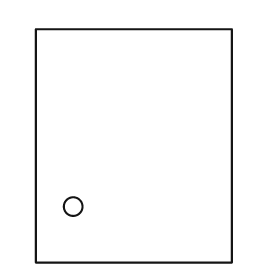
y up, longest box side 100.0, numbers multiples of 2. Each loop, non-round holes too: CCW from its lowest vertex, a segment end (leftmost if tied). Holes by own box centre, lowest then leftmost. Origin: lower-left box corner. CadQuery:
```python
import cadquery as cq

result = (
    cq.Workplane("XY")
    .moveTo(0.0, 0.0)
    .lineTo(84.0, 0.0)
    .lineTo(84.0, 100.0)
    .lineTo(0.0, 100.0)
    .close()
    .moveTo(16.0, 24.0)
    .circle(4.0)
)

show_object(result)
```